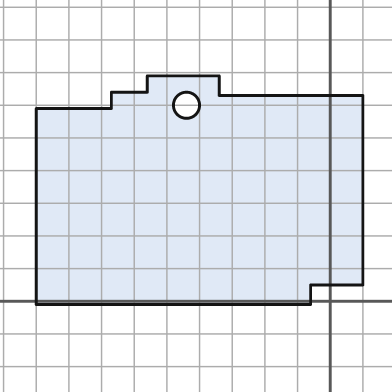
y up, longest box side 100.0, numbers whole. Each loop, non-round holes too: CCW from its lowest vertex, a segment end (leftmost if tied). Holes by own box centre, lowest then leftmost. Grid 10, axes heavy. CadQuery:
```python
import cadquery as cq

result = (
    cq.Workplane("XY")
    .moveTo(-90.0, -1.0)
    .lineTo(-6.0, -1.0)
    .lineTo(-6.0, 5.0)
    .lineTo(10.0, 5.0)
    .lineTo(10.0, 63.0)
    .lineTo(-34.0, 63.0)
    .lineTo(-34.0, 69.0)
    .lineTo(-56.0, 69.0)
    .lineTo(-56.0, 64.0)
    .lineTo(-67.0, 64.0)
    .lineTo(-67.0, 59.0)
    .lineTo(-90.0, 59.0)
    .close()
    .moveTo(-44.0, 60.0)
    .circle(4.0)
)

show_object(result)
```